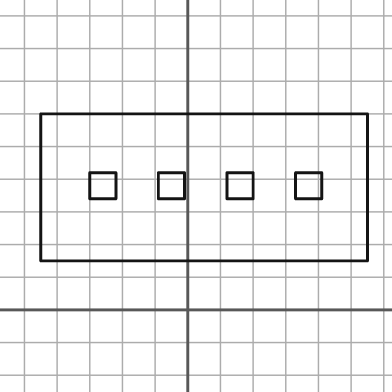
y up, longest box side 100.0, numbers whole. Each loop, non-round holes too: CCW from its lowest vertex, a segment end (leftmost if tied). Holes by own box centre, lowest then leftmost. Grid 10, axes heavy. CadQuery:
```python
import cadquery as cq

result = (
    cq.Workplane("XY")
    .moveTo(-45.0, 15.0)
    .lineTo(55.0, 15.0)
    .lineTo(55.0, 60.0)
    .lineTo(-45.0, 60.0)
    .close()
    .moveTo(-30.0, 34.0)
    .lineTo(-22.0, 34.0)
    .lineTo(-22.0, 42.0)
    .lineTo(-30.0, 42.0)
    .close()
    .moveTo(-9.0, 34.0)
    .lineTo(-1.0, 34.0)
    .lineTo(-1.0, 42.0)
    .lineTo(-9.0, 42.0)
    .close()
    .moveTo(12.0, 34.0)
    .lineTo(20.0, 34.0)
    .lineTo(20.0, 42.0)
    .lineTo(12.0, 42.0)
    .close()
    .moveTo(33.0, 34.0)
    .lineTo(41.0, 34.0)
    .lineTo(41.0, 42.0)
    .lineTo(33.0, 42.0)
    .close()
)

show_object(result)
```